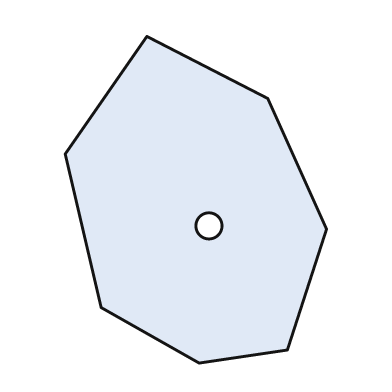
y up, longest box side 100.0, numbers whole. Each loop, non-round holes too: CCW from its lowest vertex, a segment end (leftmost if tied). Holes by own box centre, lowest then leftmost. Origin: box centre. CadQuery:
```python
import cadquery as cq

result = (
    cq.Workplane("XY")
    .moveTo(1.0, -50.0)
    .lineTo(28.0, -46.0)
    .lineTo(40.0, -9.0)
    .lineTo(22.0, 31.0)
    .lineTo(-15.0, 50.0)
    .lineTo(-40.0, 14.0)
    .lineTo(-29.0, -33.0)
    .close()
    .moveTo(4.0, -8.0)
    .circle(4.0)
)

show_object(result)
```